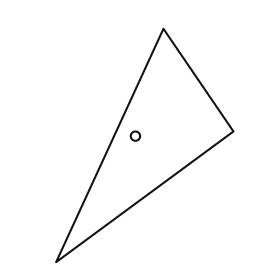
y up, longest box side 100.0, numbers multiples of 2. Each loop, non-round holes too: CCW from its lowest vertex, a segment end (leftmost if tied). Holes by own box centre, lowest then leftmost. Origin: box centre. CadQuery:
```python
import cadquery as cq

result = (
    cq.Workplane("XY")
    .moveTo(-38.0, -50.0)
    .lineTo(38.0, 6.0)
    .lineTo(8.0, 50.0)
    .close()
    .moveTo(-4.0, 4.0)
    .circle(2.0)
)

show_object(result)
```